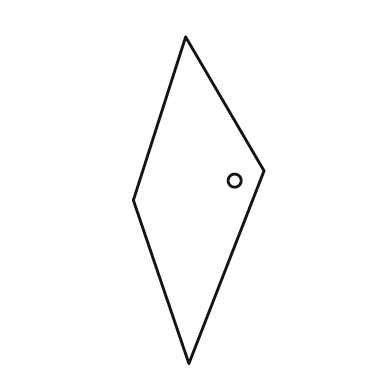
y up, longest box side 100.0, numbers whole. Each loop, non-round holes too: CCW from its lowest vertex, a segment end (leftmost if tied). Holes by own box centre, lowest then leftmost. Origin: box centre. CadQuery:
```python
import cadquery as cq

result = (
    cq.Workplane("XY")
    .moveTo(-3.0, -50.0)
    .lineTo(20.0, 9.0)
    .lineTo(-4.0, 50.0)
    .lineTo(-20.0, 0.0)
    .close()
    .moveTo(11.0, 6.0)
    .circle(2.0)
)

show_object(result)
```